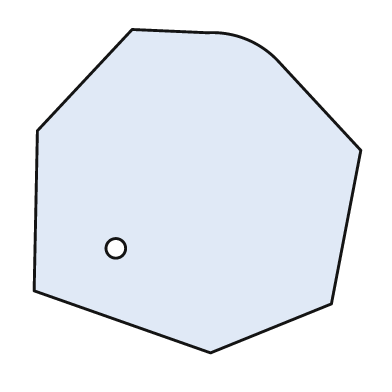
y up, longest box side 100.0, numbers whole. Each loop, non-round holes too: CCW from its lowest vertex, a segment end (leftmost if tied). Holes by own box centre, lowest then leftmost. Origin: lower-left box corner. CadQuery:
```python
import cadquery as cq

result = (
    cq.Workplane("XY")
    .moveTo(54.0, 0.0)
    .lineTo(91.0, 15.0)
    .lineTo(100.0, 62.0)
    .lineTo(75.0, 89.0)
    .threePointArc((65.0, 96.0), (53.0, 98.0))
    .lineTo(30.0, 99.0)
    .lineTo(1.0, 68.0)
    .lineTo(0.0, 19.0)
    .close()
    .moveTo(25.0, 32.0)
    .circle(3.0)
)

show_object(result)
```